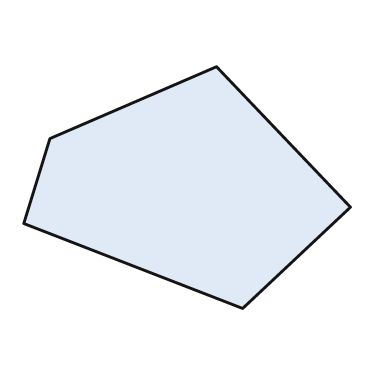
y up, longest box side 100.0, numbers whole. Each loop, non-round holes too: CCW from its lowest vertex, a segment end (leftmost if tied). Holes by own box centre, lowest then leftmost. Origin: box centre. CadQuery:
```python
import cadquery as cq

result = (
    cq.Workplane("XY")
    .moveTo(17.0, -37.0)
    .lineTo(50.0, -6.0)
    .lineTo(9.0, 37.0)
    .lineTo(-42.0, 15.0)
    .lineTo(-50.0, -11.0)
    .close()
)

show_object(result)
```